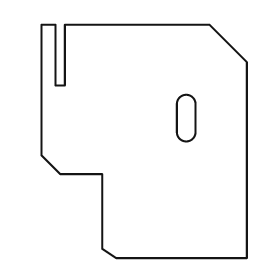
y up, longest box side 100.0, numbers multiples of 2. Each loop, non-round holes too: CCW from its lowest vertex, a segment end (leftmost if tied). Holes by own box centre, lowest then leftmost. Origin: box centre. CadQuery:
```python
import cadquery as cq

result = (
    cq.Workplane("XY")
    .moveTo(-12.0, -50.0)
    .lineTo(44.0, -50.0)
    .lineTo(44.0, 34.0)
    .lineTo(28.0, 50.0)
    .lineTo(-34.0, 50.0)
    .lineTo(-34.0, 24.0)
    .lineTo(-38.0, 24.0)
    .lineTo(-38.0, 50.0)
    .lineTo(-44.0, 50.0)
    .lineTo(-44.0, -6.0)
    .lineTo(-36.0, -14.0)
    .lineTo(-18.0, -14.0)
    .lineTo(-18.0, -46.0)
    .close()
    .moveTo(14.0, 4.0)
    .threePointArc((18.0, 0.0), (22.0, 4.0))
    .lineTo(22.0, 16.0)
    .threePointArc((18.0, 20.0), (14.0, 16.0))
    .close()
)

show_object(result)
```